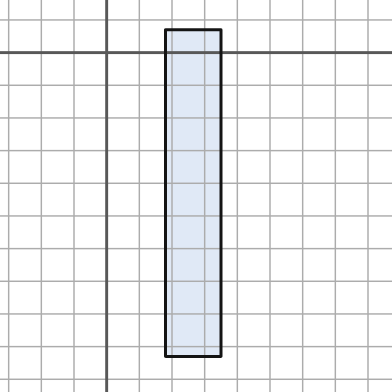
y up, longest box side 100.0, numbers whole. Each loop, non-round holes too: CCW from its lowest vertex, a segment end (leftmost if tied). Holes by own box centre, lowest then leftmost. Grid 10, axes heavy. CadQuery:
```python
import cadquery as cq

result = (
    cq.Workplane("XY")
    .moveTo(18.0, -93.0)
    .lineTo(35.0, -93.0)
    .lineTo(35.0, 7.0)
    .lineTo(18.0, 7.0)
    .close()
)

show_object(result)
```